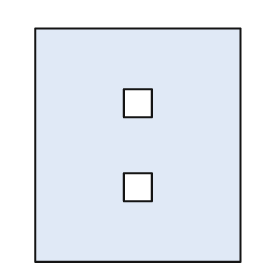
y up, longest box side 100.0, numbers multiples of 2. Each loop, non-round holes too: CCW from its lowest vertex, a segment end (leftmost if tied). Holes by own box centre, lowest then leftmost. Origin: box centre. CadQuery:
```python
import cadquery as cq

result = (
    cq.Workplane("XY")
    .moveTo(-44.0, -50.0)
    .lineTo(44.0, -50.0)
    .lineTo(44.0, 50.0)
    .lineTo(-44.0, 50.0)
    .close()
    .moveTo(-6.0, -24.0)
    .lineTo(6.0, -24.0)
    .lineTo(6.0, -12.0)
    .lineTo(-6.0, -12.0)
    .close()
    .moveTo(-6.0, 12.0)
    .lineTo(6.0, 12.0)
    .lineTo(6.0, 24.0)
    .lineTo(-6.0, 24.0)
    .close()
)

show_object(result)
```